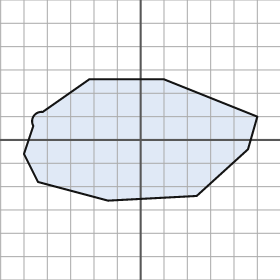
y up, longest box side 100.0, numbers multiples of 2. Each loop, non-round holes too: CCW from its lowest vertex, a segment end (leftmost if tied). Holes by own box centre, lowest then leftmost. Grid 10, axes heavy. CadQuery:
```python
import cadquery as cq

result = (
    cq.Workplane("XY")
    .moveTo(-14.0, -26.0)
    .lineTo(24.0, -24.0)
    .lineTo(46.0, -4.0)
    .lineTo(50.0, 10.0)
    .lineTo(10.0, 26.0)
    .lineTo(-22.0, 26.0)
    .lineTo(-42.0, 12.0)
    .threePointArc((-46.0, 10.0), (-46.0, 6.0))
    .lineTo(-50.0, -6.0)
    .lineTo(-44.0, -18.0)
    .close()
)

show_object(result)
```